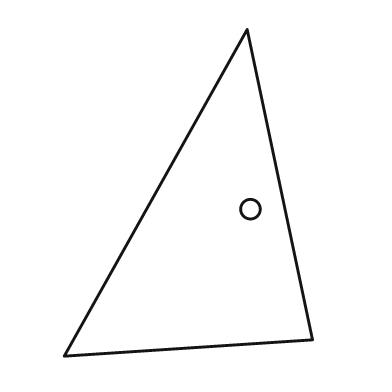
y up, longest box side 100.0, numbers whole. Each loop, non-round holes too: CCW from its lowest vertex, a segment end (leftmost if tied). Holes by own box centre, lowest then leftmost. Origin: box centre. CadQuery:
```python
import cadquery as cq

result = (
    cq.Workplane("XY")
    .moveTo(-38.0, -50.0)
    .lineTo(38.0, -45.0)
    .lineTo(18.0, 50.0)
    .close()
    .moveTo(19.0, -5.0)
    .circle(3.0)
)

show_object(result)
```